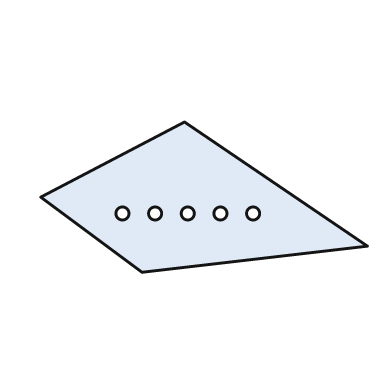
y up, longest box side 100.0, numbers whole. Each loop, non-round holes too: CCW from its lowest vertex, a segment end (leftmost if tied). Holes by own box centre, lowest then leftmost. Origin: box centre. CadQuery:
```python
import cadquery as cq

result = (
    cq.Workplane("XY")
    .moveTo(-19.0, -23.0)
    .lineTo(50.0, -15.0)
    .lineTo(-6.0, 23.0)
    .lineTo(-50.0, 0.0)
    .close()
    .moveTo(-25.0, -5.0)
    .circle(2.0)
    .moveTo(-15.0, -5.0)
    .circle(2.0)
    .moveTo(-5.0, -5.0)
    .circle(2.0)
    .moveTo(5.0, -5.0)
    .circle(2.0)
    .moveTo(15.0, -5.0)
    .circle(2.0)
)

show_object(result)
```